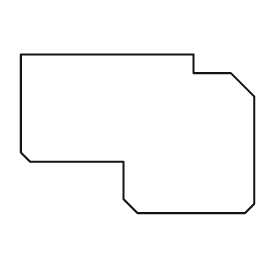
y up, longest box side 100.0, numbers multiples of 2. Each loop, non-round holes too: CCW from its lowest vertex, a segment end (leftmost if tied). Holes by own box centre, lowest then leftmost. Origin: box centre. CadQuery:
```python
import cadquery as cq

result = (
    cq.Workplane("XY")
    .moveTo(0.0, -34.0)
    .lineTo(46.0, -34.0)
    .lineTo(50.0, -30.0)
    .lineTo(50.0, 16.0)
    .lineTo(40.0, 26.0)
    .lineTo(24.0, 26.0)
    .lineTo(24.0, 34.0)
    .lineTo(-50.0, 34.0)
    .lineTo(-50.0, -8.0)
    .lineTo(-46.0, -12.0)
    .lineTo(-6.0, -12.0)
    .lineTo(-6.0, -28.0)
    .close()
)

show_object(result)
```